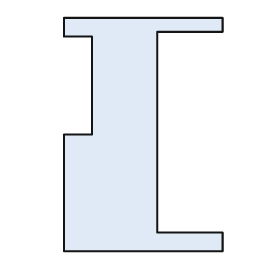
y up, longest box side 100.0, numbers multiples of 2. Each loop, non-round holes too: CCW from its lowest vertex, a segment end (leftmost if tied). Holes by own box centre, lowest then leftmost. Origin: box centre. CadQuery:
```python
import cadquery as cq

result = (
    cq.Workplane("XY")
    .moveTo(-34.0, -50.0)
    .lineTo(34.0, -50.0)
    .lineTo(34.0, -42.0)
    .lineTo(6.0, -42.0)
    .lineTo(6.0, 44.0)
    .lineTo(34.0, 44.0)
    .lineTo(34.0, 50.0)
    .lineTo(-34.0, 50.0)
    .lineTo(-34.0, 42.0)
    .lineTo(-22.0, 42.0)
    .lineTo(-22.0, 0.0)
    .lineTo(-34.0, 0.0)
    .close()
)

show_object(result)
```